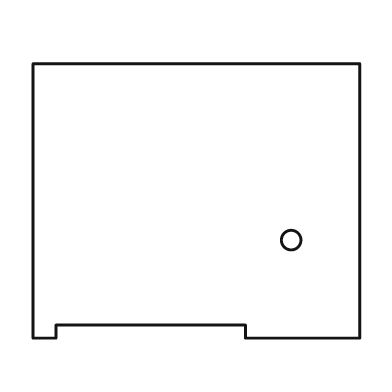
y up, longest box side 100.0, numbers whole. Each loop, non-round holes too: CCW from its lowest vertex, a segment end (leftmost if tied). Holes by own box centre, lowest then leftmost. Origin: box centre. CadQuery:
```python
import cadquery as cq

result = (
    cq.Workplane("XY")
    .moveTo(-50.0, -42.0)
    .lineTo(-43.0, -42.0)
    .lineTo(-43.0, -38.0)
    .lineTo(15.0, -38.0)
    .lineTo(15.0, -42.0)
    .lineTo(50.0, -42.0)
    .lineTo(50.0, 42.0)
    .lineTo(-50.0, 42.0)
    .close()
    .moveTo(29.0, -12.0)
    .circle(3.0)
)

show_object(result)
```